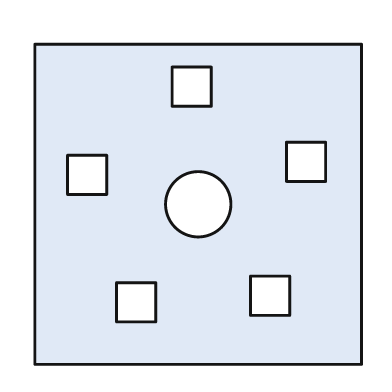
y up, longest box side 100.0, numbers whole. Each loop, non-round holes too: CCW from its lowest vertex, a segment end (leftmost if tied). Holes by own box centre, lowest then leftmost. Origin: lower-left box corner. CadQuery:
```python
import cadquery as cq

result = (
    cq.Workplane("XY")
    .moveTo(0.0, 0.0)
    .lineTo(100.0, 0.0)
    .lineTo(100.0, 98.0)
    .lineTo(0.0, 98.0)
    .close()
    .moveTo(25.0, 13.0)
    .lineTo(37.0, 13.0)
    .lineTo(37.0, 25.0)
    .lineTo(25.0, 25.0)
    .close()
    .moveTo(66.0, 15.0)
    .lineTo(78.0, 15.0)
    .lineTo(78.0, 27.0)
    .lineTo(66.0, 27.0)
    .close()
    .moveTo(50.0, 49.0)
    .circle(10.0)
    .moveTo(10.0, 52.0)
    .lineTo(22.0, 52.0)
    .lineTo(22.0, 64.0)
    .lineTo(10.0, 64.0)
    .close()
    .moveTo(77.0, 56.0)
    .lineTo(89.0, 56.0)
    .lineTo(89.0, 68.0)
    .lineTo(77.0, 68.0)
    .close()
    .moveTo(42.0, 79.0)
    .lineTo(54.0, 79.0)
    .lineTo(54.0, 91.0)
    .lineTo(42.0, 91.0)
    .close()
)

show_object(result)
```